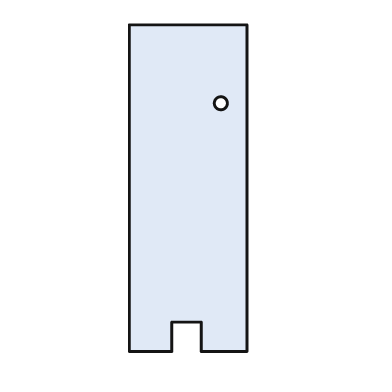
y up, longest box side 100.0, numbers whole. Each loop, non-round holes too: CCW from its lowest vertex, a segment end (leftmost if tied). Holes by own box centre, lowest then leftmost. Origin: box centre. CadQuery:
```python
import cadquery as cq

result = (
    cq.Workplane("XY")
    .moveTo(-18.0, -50.0)
    .lineTo(-5.0, -50.0)
    .lineTo(-5.0, -41.0)
    .lineTo(4.0, -41.0)
    .lineTo(4.0, -50.0)
    .lineTo(18.0, -50.0)
    .lineTo(18.0, 50.0)
    .lineTo(-18.0, 50.0)
    .close()
    .moveTo(10.0, 26.0)
    .circle(2.0)
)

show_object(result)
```